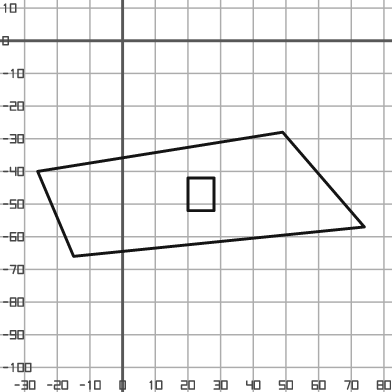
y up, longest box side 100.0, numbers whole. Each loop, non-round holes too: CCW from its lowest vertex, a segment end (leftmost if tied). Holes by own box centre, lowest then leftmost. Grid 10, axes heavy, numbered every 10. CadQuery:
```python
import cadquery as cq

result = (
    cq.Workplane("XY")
    .moveTo(-15.0, -66.0)
    .lineTo(74.0, -57.0)
    .lineTo(49.0, -28.0)
    .lineTo(-26.0, -40.0)
    .close()
    .moveTo(20.0, -52.0)
    .lineTo(28.0, -52.0)
    .lineTo(28.0, -42.0)
    .lineTo(20.0, -42.0)
    .close()
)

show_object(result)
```